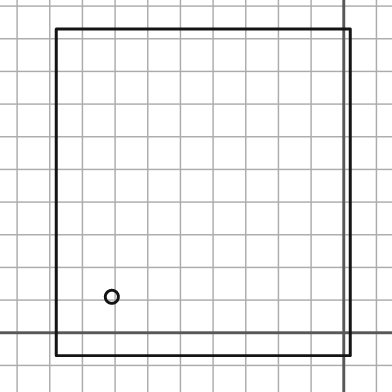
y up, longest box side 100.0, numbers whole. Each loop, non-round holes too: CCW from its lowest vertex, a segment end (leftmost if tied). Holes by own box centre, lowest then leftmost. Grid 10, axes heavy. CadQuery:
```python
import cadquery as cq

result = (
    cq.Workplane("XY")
    .moveTo(-88.0, -7.0)
    .lineTo(2.0, -7.0)
    .lineTo(2.0, 93.0)
    .lineTo(-88.0, 93.0)
    .close()
    .moveTo(-71.0, 11.0)
    .circle(2.0)
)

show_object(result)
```